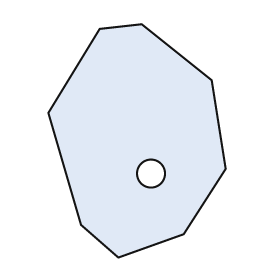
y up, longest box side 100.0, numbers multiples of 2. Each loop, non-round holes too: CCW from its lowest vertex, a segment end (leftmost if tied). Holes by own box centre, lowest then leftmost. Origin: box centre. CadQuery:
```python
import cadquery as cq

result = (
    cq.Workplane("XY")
    .moveTo(-8.0, -50.0)
    .lineTo(20.0, -40.0)
    .lineTo(38.0, -12.0)
    .lineTo(32.0, 26.0)
    .lineTo(2.0, 50.0)
    .lineTo(-16.0, 48.0)
    .lineTo(-38.0, 12.0)
    .lineTo(-24.0, -36.0)
    .close()
    .moveTo(6.0, -14.0)
    .circle(6.0)
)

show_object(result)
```